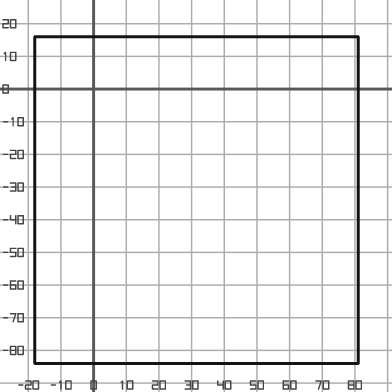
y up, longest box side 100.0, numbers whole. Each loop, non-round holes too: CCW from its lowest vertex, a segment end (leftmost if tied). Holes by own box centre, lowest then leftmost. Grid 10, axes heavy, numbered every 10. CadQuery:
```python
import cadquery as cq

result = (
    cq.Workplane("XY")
    .moveTo(-18.0, -84.0)
    .lineTo(81.0, -84.0)
    .lineTo(81.0, 16.0)
    .lineTo(-18.0, 16.0)
    .close()
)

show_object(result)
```